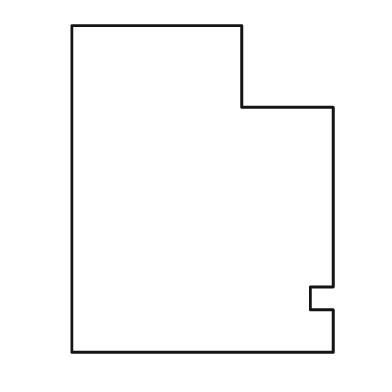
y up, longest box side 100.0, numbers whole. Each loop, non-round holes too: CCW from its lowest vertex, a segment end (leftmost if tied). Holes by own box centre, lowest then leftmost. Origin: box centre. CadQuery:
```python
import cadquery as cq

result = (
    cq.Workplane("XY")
    .moveTo(-40.0, -50.0)
    .lineTo(40.0, -50.0)
    .lineTo(40.0, -37.0)
    .lineTo(33.0, -37.0)
    .lineTo(33.0, -30.0)
    .lineTo(40.0, -30.0)
    .lineTo(40.0, 25.0)
    .lineTo(12.0, 25.0)
    .lineTo(12.0, 50.0)
    .lineTo(-40.0, 50.0)
    .close()
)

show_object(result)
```